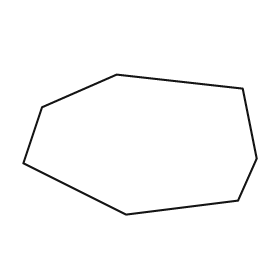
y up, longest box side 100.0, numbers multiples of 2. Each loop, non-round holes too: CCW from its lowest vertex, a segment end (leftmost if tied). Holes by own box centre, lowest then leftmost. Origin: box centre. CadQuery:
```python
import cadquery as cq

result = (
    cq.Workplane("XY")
    .moveTo(-6.0, -30.0)
    .lineTo(42.0, -24.0)
    .lineTo(50.0, -6.0)
    .lineTo(44.0, 24.0)
    .lineTo(-10.0, 30.0)
    .lineTo(-42.0, 16.0)
    .lineTo(-50.0, -8.0)
    .close()
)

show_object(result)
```